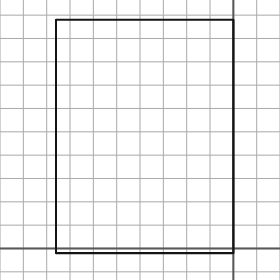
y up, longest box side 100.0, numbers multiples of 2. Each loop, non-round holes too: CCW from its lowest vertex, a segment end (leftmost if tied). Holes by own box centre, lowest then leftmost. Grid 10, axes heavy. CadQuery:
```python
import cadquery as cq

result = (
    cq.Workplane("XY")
    .moveTo(-76.0, -2.0)
    .lineTo(0.0, -2.0)
    .lineTo(0.0, 98.0)
    .lineTo(-76.0, 98.0)
    .close()
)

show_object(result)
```